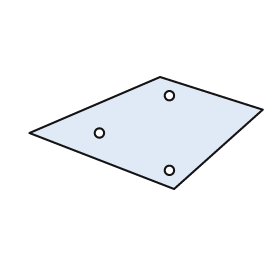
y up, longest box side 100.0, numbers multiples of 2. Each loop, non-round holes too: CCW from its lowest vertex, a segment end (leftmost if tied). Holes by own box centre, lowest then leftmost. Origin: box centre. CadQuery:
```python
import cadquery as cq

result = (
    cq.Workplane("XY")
    .moveTo(12.0, -24.0)
    .lineTo(50.0, 10.0)
    .lineTo(6.0, 24.0)
    .lineTo(-50.0, 0.0)
    .close()
    .moveTo(10.0, -16.0)
    .circle(2.0)
    .moveTo(-20.0, 0.0)
    .circle(2.0)
    .moveTo(10.0, 16.0)
    .circle(2.0)
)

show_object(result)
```